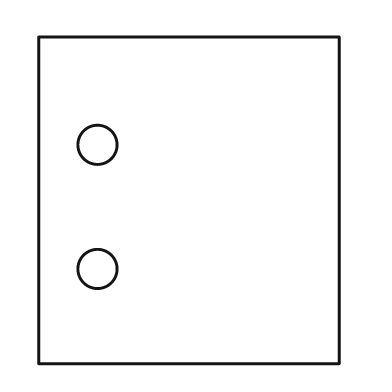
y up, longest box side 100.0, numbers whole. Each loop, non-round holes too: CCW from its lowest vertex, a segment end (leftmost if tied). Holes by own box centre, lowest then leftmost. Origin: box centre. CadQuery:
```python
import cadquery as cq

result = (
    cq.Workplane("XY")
    .moveTo(-46.0, -50.0)
    .lineTo(46.0, -50.0)
    .lineTo(46.0, 50.0)
    .lineTo(-46.0, 50.0)
    .close()
    .moveTo(-28.0, -21.0)
    .circle(6.0)
    .moveTo(-28.0, 17.0)
    .circle(6.0)
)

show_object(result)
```